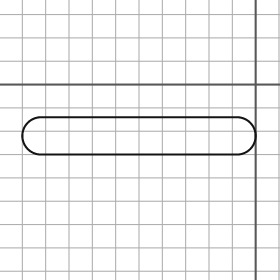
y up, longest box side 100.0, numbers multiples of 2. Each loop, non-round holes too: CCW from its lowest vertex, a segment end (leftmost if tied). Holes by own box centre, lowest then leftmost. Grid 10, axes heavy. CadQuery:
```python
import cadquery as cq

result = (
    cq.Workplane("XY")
    .moveTo(-92.0, -30.0)
    .lineTo(-8.0, -30.0)
    .threePointArc((0.0, -22.0), (-8.0, -14.0))
    .lineTo(-92.0, -14.0)
    .threePointArc((-100.0, -22.0), (-92.0, -30.0))
    .close()
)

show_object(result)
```